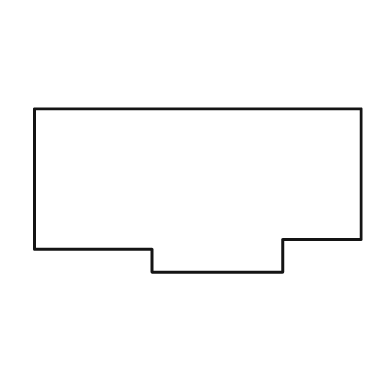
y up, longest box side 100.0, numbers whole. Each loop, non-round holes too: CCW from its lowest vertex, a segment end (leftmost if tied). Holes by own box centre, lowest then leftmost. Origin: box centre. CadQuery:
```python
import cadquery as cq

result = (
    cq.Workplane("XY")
    .moveTo(-14.0, -25.0)
    .lineTo(26.0, -25.0)
    .lineTo(26.0, -15.0)
    .lineTo(50.0, -15.0)
    .lineTo(50.0, 25.0)
    .lineTo(-50.0, 25.0)
    .lineTo(-50.0, -18.0)
    .lineTo(-14.0, -18.0)
    .close()
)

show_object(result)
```